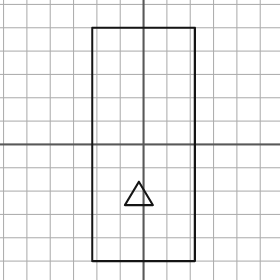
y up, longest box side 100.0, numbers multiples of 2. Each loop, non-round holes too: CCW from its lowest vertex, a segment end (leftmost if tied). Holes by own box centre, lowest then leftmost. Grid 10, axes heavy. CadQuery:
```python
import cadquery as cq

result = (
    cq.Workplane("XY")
    .moveTo(-22.0, -50.0)
    .lineTo(22.0, -50.0)
    .lineTo(22.0, 50.0)
    .lineTo(-22.0, 50.0)
    .close()
    .moveTo(-8.0, -26.0)
    .lineTo(4.0, -26.0)
    .lineTo(-2.0, -16.0)
    .close()
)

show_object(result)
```